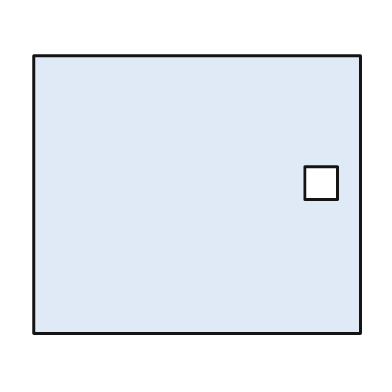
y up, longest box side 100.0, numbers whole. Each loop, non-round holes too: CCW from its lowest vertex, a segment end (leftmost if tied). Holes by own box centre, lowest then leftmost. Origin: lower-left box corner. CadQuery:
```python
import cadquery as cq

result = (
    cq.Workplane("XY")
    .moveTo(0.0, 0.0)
    .lineTo(100.0, 0.0)
    .lineTo(100.0, 85.0)
    .lineTo(0.0, 85.0)
    .close()
    .moveTo(83.0, 41.0)
    .lineTo(93.0, 41.0)
    .lineTo(93.0, 51.0)
    .lineTo(83.0, 51.0)
    .close()
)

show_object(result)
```